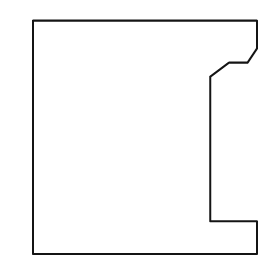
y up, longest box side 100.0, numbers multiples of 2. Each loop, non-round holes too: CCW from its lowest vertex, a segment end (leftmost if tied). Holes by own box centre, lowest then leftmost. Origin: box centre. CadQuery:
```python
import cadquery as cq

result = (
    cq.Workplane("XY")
    .moveTo(-48.0, -50.0)
    .lineTo(48.0, -50.0)
    .lineTo(48.0, -36.0)
    .lineTo(28.0, -36.0)
    .lineTo(28.0, 26.0)
    .lineTo(36.0, 32.0)
    .lineTo(44.0, 32.0)
    .lineTo(48.0, 38.0)
    .lineTo(48.0, 50.0)
    .lineTo(-48.0, 50.0)
    .close()
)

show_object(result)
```